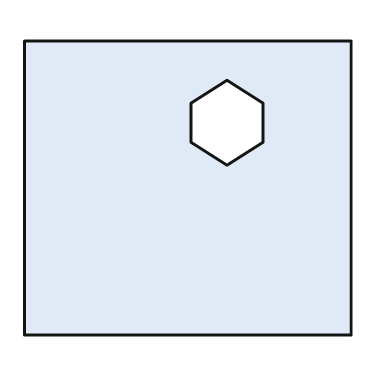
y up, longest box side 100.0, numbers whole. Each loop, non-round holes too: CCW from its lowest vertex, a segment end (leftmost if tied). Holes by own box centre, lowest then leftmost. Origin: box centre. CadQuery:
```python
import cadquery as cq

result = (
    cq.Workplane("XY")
    .moveTo(-50.0, -45.0)
    .lineTo(50.0, -45.0)
    .lineTo(50.0, 45.0)
    .lineTo(-50.0, 45.0)
    .close()
    .moveTo(12.0, 7.0)
    .lineTo(23.0, 14.0)
    .lineTo(23.0, 26.0)
    .lineTo(12.0, 33.0)
    .lineTo(1.0, 26.0)
    .lineTo(1.0, 14.0)
    .close()
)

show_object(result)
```